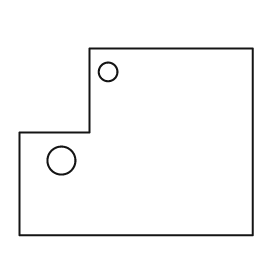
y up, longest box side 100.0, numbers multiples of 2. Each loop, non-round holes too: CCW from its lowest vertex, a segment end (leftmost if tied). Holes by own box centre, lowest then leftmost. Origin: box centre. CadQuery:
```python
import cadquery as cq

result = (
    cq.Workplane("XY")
    .moveTo(-50.0, -40.0)
    .lineTo(50.0, -40.0)
    .lineTo(50.0, 40.0)
    .lineTo(-20.0, 40.0)
    .lineTo(-20.0, 4.0)
    .lineTo(-50.0, 4.0)
    .close()
    .moveTo(-32.0, -8.0)
    .circle(6.0)
    .moveTo(-12.0, 30.0)
    .circle(4.0)
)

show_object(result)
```